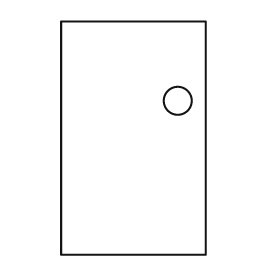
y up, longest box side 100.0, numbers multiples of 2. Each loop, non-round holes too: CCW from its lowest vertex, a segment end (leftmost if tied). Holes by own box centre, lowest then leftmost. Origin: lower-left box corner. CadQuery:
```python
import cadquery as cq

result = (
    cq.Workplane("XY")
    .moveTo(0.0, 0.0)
    .lineTo(62.0, 0.0)
    .lineTo(62.0, 100.0)
    .lineTo(0.0, 100.0)
    .close()
    .moveTo(50.0, 66.0)
    .circle(6.0)
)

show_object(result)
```